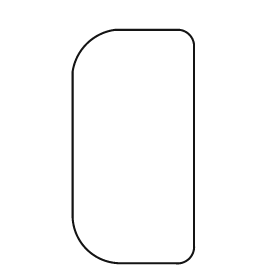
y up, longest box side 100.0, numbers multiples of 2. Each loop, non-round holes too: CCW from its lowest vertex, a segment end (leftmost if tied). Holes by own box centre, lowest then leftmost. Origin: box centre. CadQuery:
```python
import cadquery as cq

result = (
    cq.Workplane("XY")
    .moveTo(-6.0, -50.0)
    .lineTo(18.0, -50.0)
    .threePointArc((24.0, -48.0), (26.0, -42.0))
    .lineTo(26.0, 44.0)
    .threePointArc((24.0, 48.0), (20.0, 50.0))
    .lineTo(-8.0, 50.0)
    .threePointArc((-20.0, 44.0), (-26.0, 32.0))
    .lineTo(-26.0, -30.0)
    .threePointArc((-20.0, -44.0), (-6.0, -50.0))
    .close()
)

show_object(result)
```